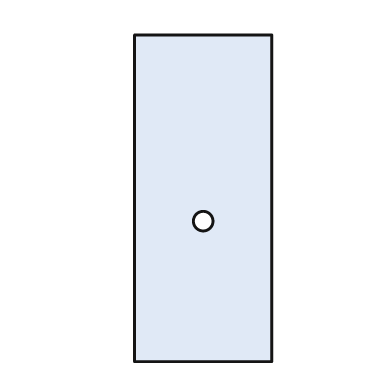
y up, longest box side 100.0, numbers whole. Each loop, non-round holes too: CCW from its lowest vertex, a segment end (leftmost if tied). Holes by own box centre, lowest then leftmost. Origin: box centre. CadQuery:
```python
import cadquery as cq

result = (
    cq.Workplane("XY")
    .moveTo(-21.0, -50.0)
    .lineTo(21.0, -50.0)
    .lineTo(21.0, 50.0)
    .lineTo(-21.0, 50.0)
    .close()
    .moveTo(0.0, -7.0)
    .circle(3.0)
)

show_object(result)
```